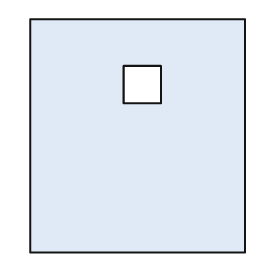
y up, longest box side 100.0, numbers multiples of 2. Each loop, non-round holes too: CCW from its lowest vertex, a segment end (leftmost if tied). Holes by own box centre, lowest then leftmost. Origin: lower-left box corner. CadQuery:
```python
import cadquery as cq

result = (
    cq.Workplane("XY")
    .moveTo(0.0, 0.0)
    .lineTo(92.0, 0.0)
    .lineTo(92.0, 100.0)
    .lineTo(0.0, 100.0)
    .close()
    .moveTo(40.0, 64.0)
    .lineTo(56.0, 64.0)
    .lineTo(56.0, 80.0)
    .lineTo(40.0, 80.0)
    .close()
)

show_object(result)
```